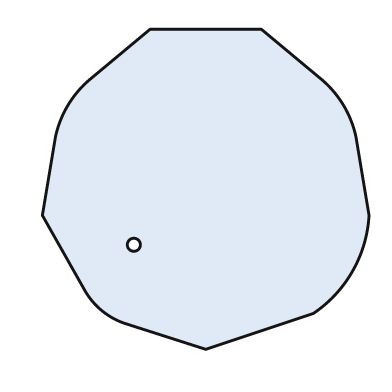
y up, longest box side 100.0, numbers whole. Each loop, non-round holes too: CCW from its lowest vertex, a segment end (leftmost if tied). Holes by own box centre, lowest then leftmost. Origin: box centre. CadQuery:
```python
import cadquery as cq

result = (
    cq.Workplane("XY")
    .moveTo(0.0, -49.0)
    .lineTo(33.0, -38.0)
    .threePointArc((45.0, -25.0), (50.0, -8.0))
    .lineTo(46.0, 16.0)
    .threePointArc((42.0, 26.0), (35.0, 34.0))
    .lineTo(17.0, 49.0)
    .lineTo(-17.0, 49.0)
    .lineTo(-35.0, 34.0)
    .threePointArc((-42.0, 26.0), (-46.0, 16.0))
    .lineTo(-50.0, -8.0)
    .lineTo(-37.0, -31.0)
    .threePointArc((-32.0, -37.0), (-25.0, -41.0))
    .close()
    .moveTo(-22.0, -17.0)
    .circle(2.0)
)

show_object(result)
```